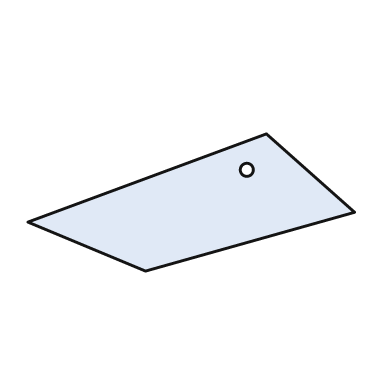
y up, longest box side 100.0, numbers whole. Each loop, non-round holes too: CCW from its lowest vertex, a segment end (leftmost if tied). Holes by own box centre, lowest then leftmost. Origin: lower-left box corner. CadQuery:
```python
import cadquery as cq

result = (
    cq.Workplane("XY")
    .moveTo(36.0, 0.0)
    .lineTo(100.0, 18.0)
    .lineTo(73.0, 42.0)
    .lineTo(0.0, 15.0)
    .close()
    .moveTo(67.0, 31.0)
    .circle(2.0)
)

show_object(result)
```